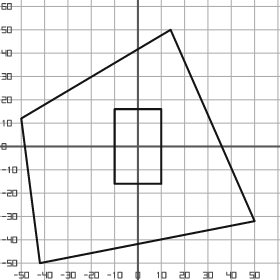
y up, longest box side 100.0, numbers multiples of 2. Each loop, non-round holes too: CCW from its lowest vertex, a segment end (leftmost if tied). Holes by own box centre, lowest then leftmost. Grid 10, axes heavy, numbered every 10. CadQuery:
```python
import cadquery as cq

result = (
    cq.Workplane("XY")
    .moveTo(-42.0, -50.0)
    .lineTo(50.0, -32.0)
    .lineTo(14.0, 50.0)
    .lineTo(-50.0, 12.0)
    .close()
    .moveTo(-10.0, -16.0)
    .lineTo(10.0, -16.0)
    .lineTo(10.0, 16.0)
    .lineTo(-10.0, 16.0)
    .close()
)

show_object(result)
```